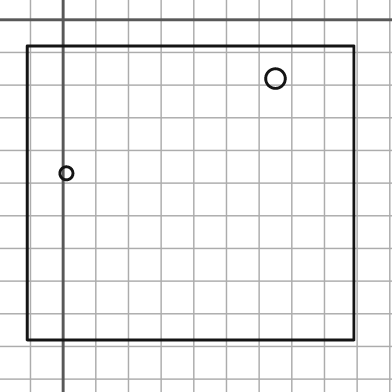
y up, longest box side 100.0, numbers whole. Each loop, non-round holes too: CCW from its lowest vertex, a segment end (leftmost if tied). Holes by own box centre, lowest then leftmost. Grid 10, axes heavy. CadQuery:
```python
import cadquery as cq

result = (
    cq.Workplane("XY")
    .moveTo(-11.0, -98.0)
    .lineTo(89.0, -98.0)
    .lineTo(89.0, -8.0)
    .lineTo(-11.0, -8.0)
    .close()
    .moveTo(1.0, -47.0)
    .circle(2.0)
    .moveTo(65.0, -18.0)
    .circle(3.0)
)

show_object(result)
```